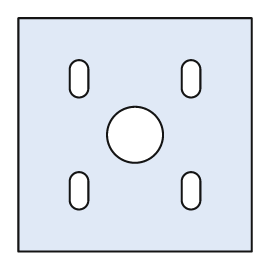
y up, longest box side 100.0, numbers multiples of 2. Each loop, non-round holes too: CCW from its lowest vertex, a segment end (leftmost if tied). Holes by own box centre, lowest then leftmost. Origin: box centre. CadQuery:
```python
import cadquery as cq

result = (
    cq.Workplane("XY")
    .moveTo(-50.0, -50.0)
    .lineTo(50.0, -50.0)
    .lineTo(50.0, 50.0)
    .lineTo(-50.0, 50.0)
    .close()
    .moveTo(-28.0, -28.0)
    .threePointArc((-24.0, -32.0), (-20.0, -28.0))
    .lineTo(-20.0, -20.0)
    .threePointArc((-24.0, -16.0), (-28.0, -20.0))
    .close()
    .moveTo(20.0, -28.0)
    .threePointArc((24.0, -32.0), (28.0, -28.0))
    .lineTo(28.0, -20.0)
    .threePointArc((24.0, -16.0), (20.0, -20.0))
    .close()
    .moveTo(0.0, 0.0)
    .circle(12.0)
    .moveTo(-28.0, 20.0)
    .threePointArc((-24.0, 16.0), (-20.0, 20.0))
    .lineTo(-20.0, 28.0)
    .threePointArc((-24.0, 32.0), (-28.0, 28.0))
    .close()
    .moveTo(20.0, 20.0)
    .threePointArc((24.0, 16.0), (28.0, 20.0))
    .lineTo(28.0, 28.0)
    .threePointArc((24.0, 32.0), (20.0, 28.0))
    .close()
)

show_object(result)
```